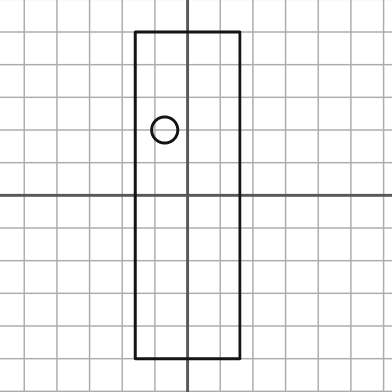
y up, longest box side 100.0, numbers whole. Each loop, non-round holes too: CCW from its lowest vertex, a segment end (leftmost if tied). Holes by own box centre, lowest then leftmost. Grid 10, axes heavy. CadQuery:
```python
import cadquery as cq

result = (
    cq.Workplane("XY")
    .moveTo(-16.0, -50.0)
    .lineTo(16.0, -50.0)
    .lineTo(16.0, 50.0)
    .lineTo(-16.0, 50.0)
    .close()
    .moveTo(-7.0, 20.0)
    .circle(4.0)
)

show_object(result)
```